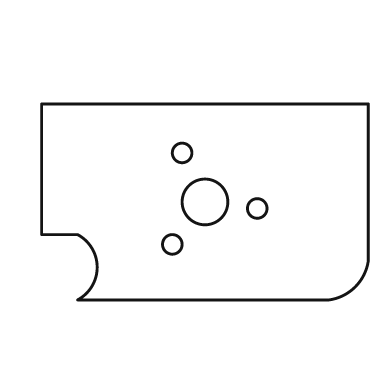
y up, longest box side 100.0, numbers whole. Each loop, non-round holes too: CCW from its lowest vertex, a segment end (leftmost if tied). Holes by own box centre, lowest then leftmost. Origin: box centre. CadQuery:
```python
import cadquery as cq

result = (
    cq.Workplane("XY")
    .moveTo(-39.0, -30.0)
    .lineTo(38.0, -30.0)
    .threePointArc((46.0, -26.0), (50.0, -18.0))
    .lineTo(50.0, 30.0)
    .lineTo(-50.0, 30.0)
    .lineTo(-50.0, -10.0)
    .lineTo(-39.0, -10.0)
    .threePointArc((-33.0, -20.0), (-39.0, -30.0))
    .close()
    .moveTo(-10.0, -13.0)
    .circle(3.0)
    .moveTo(16.0, -2.0)
    .circle(3.0)
    .moveTo(0.0, 0.0)
    .circle(7.0)
    .moveTo(-7.0, 15.0)
    .circle(3.0)
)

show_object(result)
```